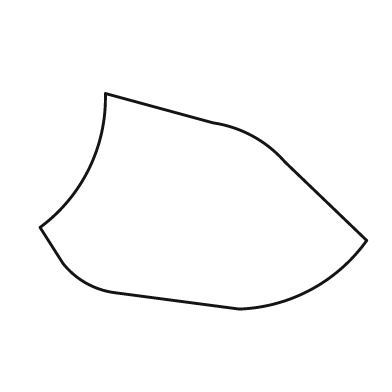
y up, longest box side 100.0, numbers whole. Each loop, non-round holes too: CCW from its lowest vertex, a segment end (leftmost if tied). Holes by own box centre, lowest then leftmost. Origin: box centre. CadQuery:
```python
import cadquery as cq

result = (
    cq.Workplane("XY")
    .moveTo(11.0, -33.0)
    .threePointArc((33.0, -27.0), (50.0, -12.0))
    .lineTo(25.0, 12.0)
    .threePointArc((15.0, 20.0), (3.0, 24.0))
    .lineTo(-30.0, 33.0)
    .threePointArc((-35.0, 10.0), (-50.0, -8.0))
    .lineTo(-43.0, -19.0)
    .threePointArc((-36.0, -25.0), (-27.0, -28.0))
    .close()
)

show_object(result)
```